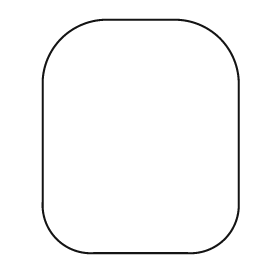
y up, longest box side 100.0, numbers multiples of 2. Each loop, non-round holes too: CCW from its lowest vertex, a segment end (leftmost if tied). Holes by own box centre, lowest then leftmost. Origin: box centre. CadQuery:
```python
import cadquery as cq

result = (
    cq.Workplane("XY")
    .moveTo(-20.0, -50.0)
    .lineTo(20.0, -50.0)
    .threePointArc((36.0, -44.0), (42.0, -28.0))
    .lineTo(42.0, 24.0)
    .threePointArc((34.0, 42.0), (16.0, 50.0))
    .lineTo(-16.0, 50.0)
    .threePointArc((-34.0, 42.0), (-42.0, 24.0))
    .lineTo(-42.0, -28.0)
    .threePointArc((-36.0, -44.0), (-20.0, -50.0))
    .close()
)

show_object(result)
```